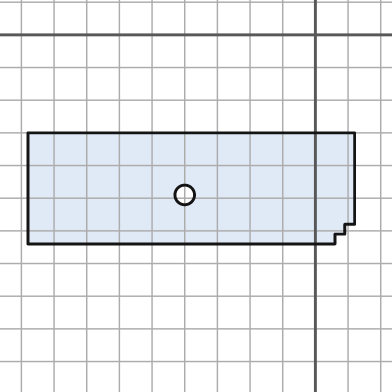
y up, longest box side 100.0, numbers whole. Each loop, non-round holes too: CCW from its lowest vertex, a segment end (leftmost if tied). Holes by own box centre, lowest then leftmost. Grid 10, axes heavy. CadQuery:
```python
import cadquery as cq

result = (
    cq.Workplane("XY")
    .moveTo(-88.0, -64.0)
    .lineTo(6.0, -64.0)
    .lineTo(6.0, -61.0)
    .lineTo(9.0, -61.0)
    .lineTo(9.0, -58.0)
    .lineTo(12.0, -58.0)
    .lineTo(12.0, -30.0)
    .lineTo(-88.0, -30.0)
    .close()
    .moveTo(-40.0, -49.0)
    .circle(3.0)
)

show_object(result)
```